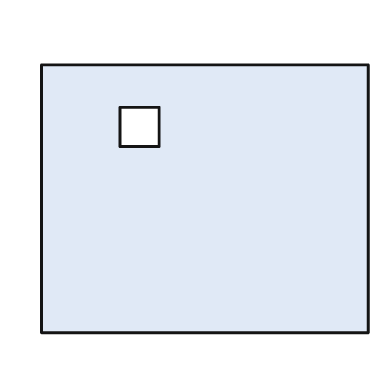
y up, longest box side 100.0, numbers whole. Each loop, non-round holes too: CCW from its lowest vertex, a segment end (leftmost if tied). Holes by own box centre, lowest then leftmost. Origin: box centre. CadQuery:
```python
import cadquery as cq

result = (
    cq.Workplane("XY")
    .moveTo(-50.0, -41.0)
    .lineTo(50.0, -41.0)
    .lineTo(50.0, 41.0)
    .lineTo(-50.0, 41.0)
    .close()
    .moveTo(-26.0, 16.0)
    .lineTo(-14.0, 16.0)
    .lineTo(-14.0, 28.0)
    .lineTo(-26.0, 28.0)
    .close()
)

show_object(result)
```